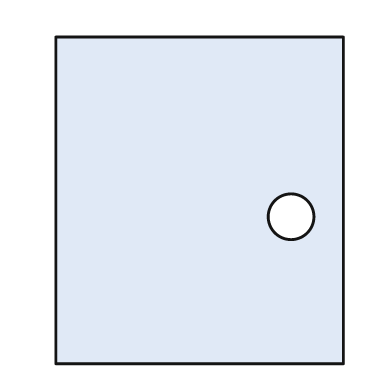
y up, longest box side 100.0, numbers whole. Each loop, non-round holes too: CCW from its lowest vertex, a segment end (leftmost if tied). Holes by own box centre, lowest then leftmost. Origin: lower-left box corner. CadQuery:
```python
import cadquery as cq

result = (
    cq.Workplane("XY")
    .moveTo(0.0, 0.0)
    .lineTo(88.0, 0.0)
    .lineTo(88.0, 100.0)
    .lineTo(0.0, 100.0)
    .close()
    .moveTo(72.0, 45.0)
    .circle(7.0)
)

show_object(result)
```